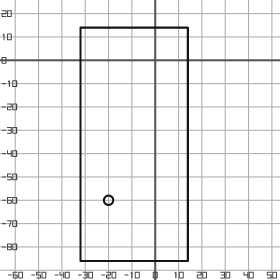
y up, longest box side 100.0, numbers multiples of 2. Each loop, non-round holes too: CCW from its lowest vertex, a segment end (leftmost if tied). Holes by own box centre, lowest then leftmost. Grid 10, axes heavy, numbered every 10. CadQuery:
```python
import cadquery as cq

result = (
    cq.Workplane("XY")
    .moveTo(-32.0, -86.0)
    .lineTo(14.0, -86.0)
    .lineTo(14.0, 14.0)
    .lineTo(-32.0, 14.0)
    .close()
    .moveTo(-20.0, -60.0)
    .circle(2.0)
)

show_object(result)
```